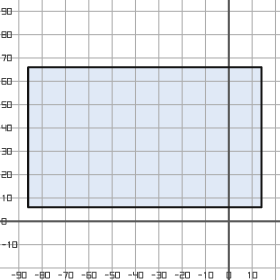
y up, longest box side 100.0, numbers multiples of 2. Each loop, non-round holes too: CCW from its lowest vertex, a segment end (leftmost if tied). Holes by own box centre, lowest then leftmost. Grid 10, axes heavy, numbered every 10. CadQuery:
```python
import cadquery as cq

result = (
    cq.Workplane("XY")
    .moveTo(-86.0, 6.0)
    .lineTo(14.0, 6.0)
    .lineTo(14.0, 66.0)
    .lineTo(-86.0, 66.0)
    .close()
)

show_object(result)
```